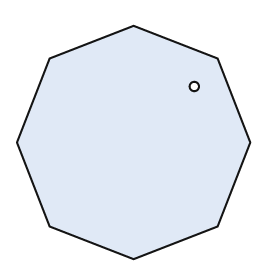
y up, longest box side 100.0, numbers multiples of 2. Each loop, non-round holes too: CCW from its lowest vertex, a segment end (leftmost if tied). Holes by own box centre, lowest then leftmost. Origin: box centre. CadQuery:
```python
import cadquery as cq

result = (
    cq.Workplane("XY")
    .moveTo(0.0, -50.0)
    .lineTo(36.0, -36.0)
    .lineTo(50.0, 0.0)
    .lineTo(36.0, 36.0)
    .lineTo(0.0, 50.0)
    .lineTo(-36.0, 36.0)
    .lineTo(-50.0, 0.0)
    .lineTo(-36.0, -36.0)
    .close()
    .moveTo(26.0, 24.0)
    .circle(2.0)
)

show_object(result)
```